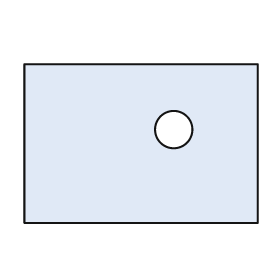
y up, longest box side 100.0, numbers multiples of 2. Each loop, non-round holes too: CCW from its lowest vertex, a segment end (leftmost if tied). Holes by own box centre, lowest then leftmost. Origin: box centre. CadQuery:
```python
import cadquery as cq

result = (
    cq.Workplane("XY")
    .moveTo(-50.0, -34.0)
    .lineTo(50.0, -34.0)
    .lineTo(50.0, 34.0)
    .lineTo(-50.0, 34.0)
    .close()
    .moveTo(14.0, 6.0)
    .circle(8.0)
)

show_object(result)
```